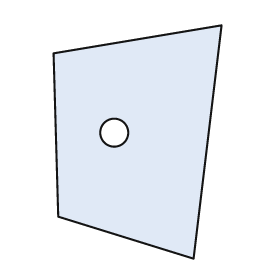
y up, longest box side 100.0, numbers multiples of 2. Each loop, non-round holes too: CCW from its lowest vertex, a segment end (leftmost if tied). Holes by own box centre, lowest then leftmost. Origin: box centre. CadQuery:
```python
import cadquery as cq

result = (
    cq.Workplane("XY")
    .moveTo(24.0, -50.0)
    .lineTo(36.0, 50.0)
    .lineTo(-36.0, 38.0)
    .lineTo(-34.0, -32.0)
    .close()
    .moveTo(-10.0, 4.0)
    .circle(6.0)
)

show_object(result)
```